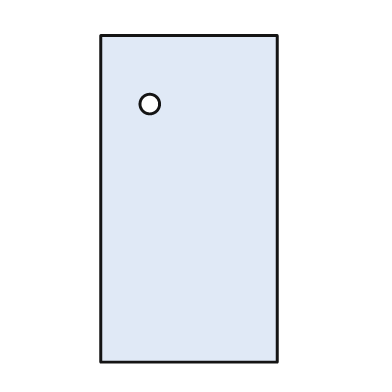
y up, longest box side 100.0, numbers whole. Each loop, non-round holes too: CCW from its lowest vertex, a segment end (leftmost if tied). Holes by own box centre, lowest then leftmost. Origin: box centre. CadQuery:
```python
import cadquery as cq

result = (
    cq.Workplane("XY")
    .moveTo(-27.0, -50.0)
    .lineTo(27.0, -50.0)
    .lineTo(27.0, 50.0)
    .lineTo(-27.0, 50.0)
    .close()
    .moveTo(-12.0, 29.0)
    .circle(3.0)
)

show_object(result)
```